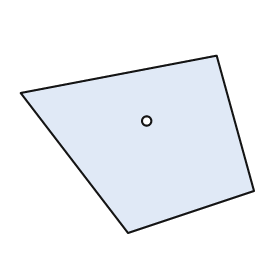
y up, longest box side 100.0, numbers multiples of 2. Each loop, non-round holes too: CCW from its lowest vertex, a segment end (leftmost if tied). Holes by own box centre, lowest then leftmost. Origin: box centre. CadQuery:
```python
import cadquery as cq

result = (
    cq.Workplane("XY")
    .moveTo(-4.0, -38.0)
    .lineTo(50.0, -20.0)
    .lineTo(34.0, 38.0)
    .lineTo(-50.0, 22.0)
    .close()
    .moveTo(4.0, 10.0)
    .circle(2.0)
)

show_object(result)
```